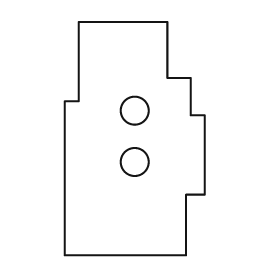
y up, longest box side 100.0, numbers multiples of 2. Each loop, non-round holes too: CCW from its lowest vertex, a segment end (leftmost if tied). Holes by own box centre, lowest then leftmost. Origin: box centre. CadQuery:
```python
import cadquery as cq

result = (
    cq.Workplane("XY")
    .moveTo(-30.0, -50.0)
    .lineTo(22.0, -50.0)
    .lineTo(22.0, -24.0)
    .lineTo(30.0, -24.0)
    .lineTo(30.0, 10.0)
    .lineTo(24.0, 10.0)
    .lineTo(24.0, 26.0)
    .lineTo(14.0, 26.0)
    .lineTo(14.0, 50.0)
    .lineTo(-24.0, 50.0)
    .lineTo(-24.0, 16.0)
    .lineTo(-30.0, 16.0)
    .close()
    .moveTo(0.0, -10.0)
    .circle(6.0)
    .moveTo(0.0, 12.0)
    .circle(6.0)
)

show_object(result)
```